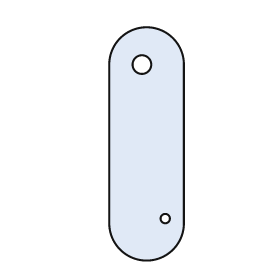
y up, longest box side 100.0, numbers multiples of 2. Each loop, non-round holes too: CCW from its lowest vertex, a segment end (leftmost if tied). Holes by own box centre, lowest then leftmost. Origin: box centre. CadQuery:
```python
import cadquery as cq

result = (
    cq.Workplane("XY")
    .moveTo(-16.0, -34.0)
    .threePointArc((0.0, -50.0), (16.0, -34.0))
    .lineTo(16.0, 34.0)
    .threePointArc((0.0, 50.0), (-16.0, 34.0))
    .close()
    .moveTo(8.0, -32.0)
    .circle(2.0)
    .moveTo(-2.0, 34.0)
    .circle(4.0)
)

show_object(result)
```